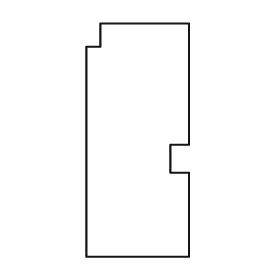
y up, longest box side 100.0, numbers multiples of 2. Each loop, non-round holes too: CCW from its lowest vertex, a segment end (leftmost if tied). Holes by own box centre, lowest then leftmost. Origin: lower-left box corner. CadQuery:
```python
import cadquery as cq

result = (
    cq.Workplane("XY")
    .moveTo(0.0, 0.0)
    .lineTo(44.0, 0.0)
    .lineTo(44.0, 36.0)
    .lineTo(36.0, 36.0)
    .lineTo(36.0, 48.0)
    .lineTo(44.0, 48.0)
    .lineTo(44.0, 100.0)
    .lineTo(6.0, 100.0)
    .lineTo(6.0, 90.0)
    .lineTo(0.0, 90.0)
    .close()
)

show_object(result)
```